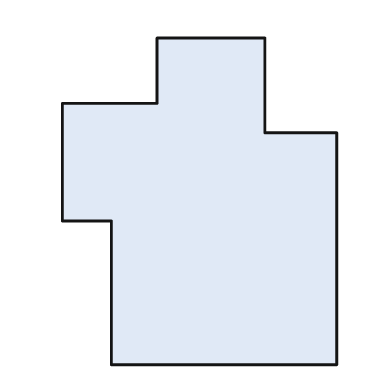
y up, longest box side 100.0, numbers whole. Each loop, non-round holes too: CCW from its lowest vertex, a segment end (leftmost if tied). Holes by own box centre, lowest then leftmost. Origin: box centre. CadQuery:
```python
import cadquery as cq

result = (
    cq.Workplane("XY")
    .moveTo(-27.0, -50.0)
    .lineTo(42.0, -50.0)
    .lineTo(42.0, 21.0)
    .lineTo(20.0, 21.0)
    .lineTo(20.0, 50.0)
    .lineTo(-13.0, 50.0)
    .lineTo(-13.0, 30.0)
    .lineTo(-42.0, 30.0)
    .lineTo(-42.0, -6.0)
    .lineTo(-27.0, -6.0)
    .close()
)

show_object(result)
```